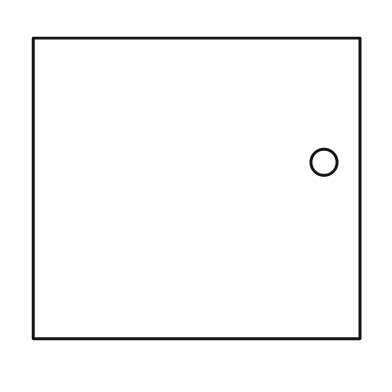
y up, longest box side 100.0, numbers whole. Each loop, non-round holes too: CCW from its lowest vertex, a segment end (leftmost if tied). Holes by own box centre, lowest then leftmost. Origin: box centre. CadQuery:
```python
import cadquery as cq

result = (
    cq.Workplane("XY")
    .moveTo(-50.0, -46.0)
    .lineTo(50.0, -46.0)
    .lineTo(50.0, 46.0)
    .lineTo(-50.0, 46.0)
    .close()
    .moveTo(39.0, 8.0)
    .circle(4.0)
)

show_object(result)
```